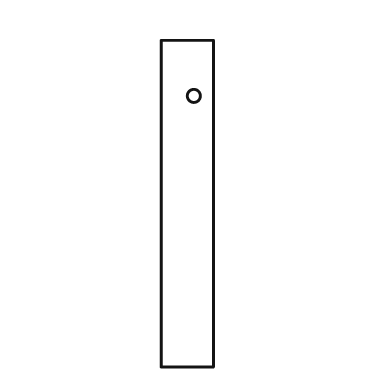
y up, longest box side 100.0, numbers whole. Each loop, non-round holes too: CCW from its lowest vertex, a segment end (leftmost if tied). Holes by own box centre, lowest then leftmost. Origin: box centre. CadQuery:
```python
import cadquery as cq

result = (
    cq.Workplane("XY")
    .moveTo(-8.0, -50.0)
    .lineTo(8.0, -50.0)
    .lineTo(8.0, 50.0)
    .lineTo(-8.0, 50.0)
    .close()
    .moveTo(2.0, 33.0)
    .circle(2.0)
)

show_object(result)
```